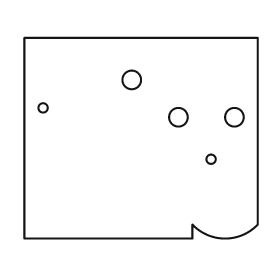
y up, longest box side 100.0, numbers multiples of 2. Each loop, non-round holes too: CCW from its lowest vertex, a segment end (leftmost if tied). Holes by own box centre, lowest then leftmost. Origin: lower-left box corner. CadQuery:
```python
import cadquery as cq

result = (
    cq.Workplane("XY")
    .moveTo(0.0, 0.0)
    .lineTo(72.0, 0.0)
    .lineTo(72.0, 6.0)
    .threePointArc((86.0, 0.0), (100.0, 6.0))
    .lineTo(100.0, 86.0)
    .lineTo(0.0, 86.0)
    .close()
    .moveTo(80.0, 34.0)
    .circle(2.0)
    .moveTo(66.0, 52.0)
    .circle(4.0)
    .moveTo(90.0, 52.0)
    .circle(4.0)
    .moveTo(8.0, 56.0)
    .circle(2.0)
    .moveTo(46.0, 68.0)
    .circle(4.0)
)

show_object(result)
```